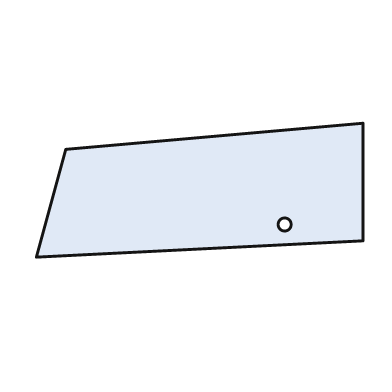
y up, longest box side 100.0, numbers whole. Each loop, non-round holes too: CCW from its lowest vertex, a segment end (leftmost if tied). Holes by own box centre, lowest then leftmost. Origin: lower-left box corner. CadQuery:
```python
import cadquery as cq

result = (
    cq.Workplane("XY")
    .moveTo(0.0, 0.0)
    .lineTo(100.0, 5.0)
    .lineTo(100.0, 41.0)
    .lineTo(9.0, 33.0)
    .close()
    .moveTo(76.0, 10.0)
    .circle(2.0)
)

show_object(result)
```